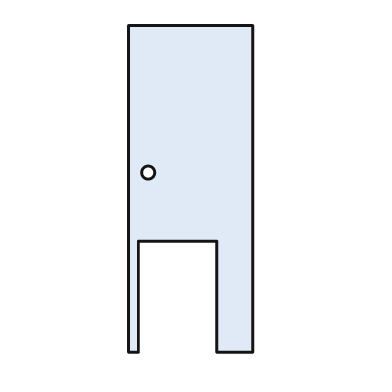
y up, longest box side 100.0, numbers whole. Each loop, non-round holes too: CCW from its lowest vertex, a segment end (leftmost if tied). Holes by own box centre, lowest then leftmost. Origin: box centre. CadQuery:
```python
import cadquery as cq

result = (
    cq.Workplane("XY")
    .moveTo(-19.0, -50.0)
    .lineTo(-16.0, -50.0)
    .lineTo(-16.0, -16.0)
    .lineTo(8.0, -16.0)
    .lineTo(8.0, -50.0)
    .lineTo(19.0, -50.0)
    .lineTo(19.0, 50.0)
    .lineTo(-19.0, 50.0)
    .close()
    .moveTo(-13.0, 5.0)
    .circle(2.0)
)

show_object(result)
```